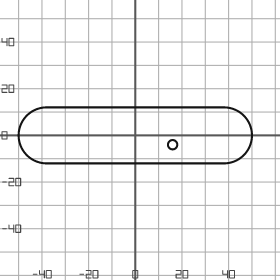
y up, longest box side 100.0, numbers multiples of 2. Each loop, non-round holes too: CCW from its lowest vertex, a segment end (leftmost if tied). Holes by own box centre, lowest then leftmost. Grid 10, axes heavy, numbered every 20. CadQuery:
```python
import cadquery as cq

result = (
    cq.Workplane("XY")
    .moveTo(-38.0, -12.0)
    .lineTo(38.0, -12.0)
    .threePointArc((50.0, 0.0), (38.0, 12.0))
    .lineTo(-38.0, 12.0)
    .threePointArc((-50.0, 0.0), (-38.0, -12.0))
    .close()
    .moveTo(16.0, -4.0)
    .circle(2.0)
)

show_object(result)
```